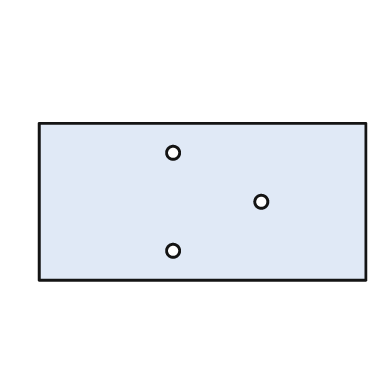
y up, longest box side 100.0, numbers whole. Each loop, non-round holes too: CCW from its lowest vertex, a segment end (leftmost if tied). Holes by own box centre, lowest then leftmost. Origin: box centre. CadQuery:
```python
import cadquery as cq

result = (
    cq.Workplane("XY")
    .moveTo(-50.0, -24.0)
    .lineTo(50.0, -24.0)
    .lineTo(50.0, 24.0)
    .lineTo(-50.0, 24.0)
    .close()
    .moveTo(-9.0, -15.0)
    .circle(2.0)
    .moveTo(18.0, 0.0)
    .circle(2.0)
    .moveTo(-9.0, 15.0)
    .circle(2.0)
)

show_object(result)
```